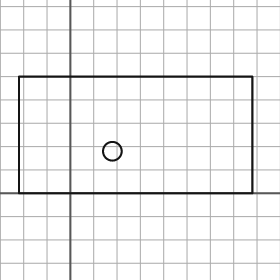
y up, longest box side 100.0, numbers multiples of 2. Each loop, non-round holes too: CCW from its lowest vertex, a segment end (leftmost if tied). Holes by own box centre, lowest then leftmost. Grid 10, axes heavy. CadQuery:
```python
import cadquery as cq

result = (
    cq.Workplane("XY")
    .moveTo(-22.0, 0.0)
    .lineTo(78.0, 0.0)
    .lineTo(78.0, 50.0)
    .lineTo(-22.0, 50.0)
    .close()
    .moveTo(18.0, 18.0)
    .circle(4.0)
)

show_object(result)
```